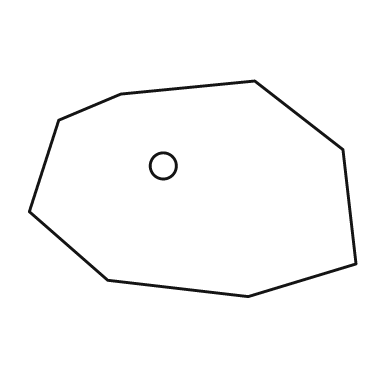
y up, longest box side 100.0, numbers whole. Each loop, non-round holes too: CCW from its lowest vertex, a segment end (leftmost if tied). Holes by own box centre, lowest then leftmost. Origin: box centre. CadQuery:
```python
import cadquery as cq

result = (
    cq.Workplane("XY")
    .moveTo(17.0, -33.0)
    .lineTo(50.0, -23.0)
    .lineTo(46.0, 12.0)
    .lineTo(19.0, 33.0)
    .lineTo(-22.0, 29.0)
    .lineTo(-41.0, 21.0)
    .lineTo(-50.0, -7.0)
    .lineTo(-26.0, -28.0)
    .close()
    .moveTo(-9.0, 7.0)
    .circle(4.0)
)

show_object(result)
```